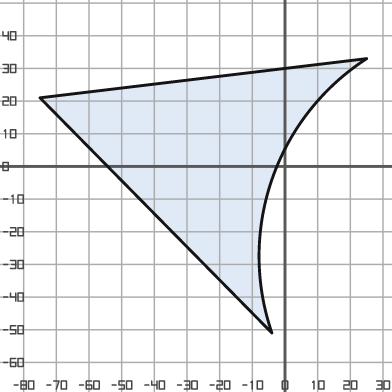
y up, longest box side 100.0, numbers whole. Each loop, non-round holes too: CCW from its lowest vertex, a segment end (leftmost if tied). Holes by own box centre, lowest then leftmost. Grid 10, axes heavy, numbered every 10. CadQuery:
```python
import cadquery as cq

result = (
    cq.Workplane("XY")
    .moveTo(-4.0, -51.0)
    .threePointArc((-4.0, -4.0), (25.0, 33.0))
    .lineTo(-75.0, 21.0)
    .close()
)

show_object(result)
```